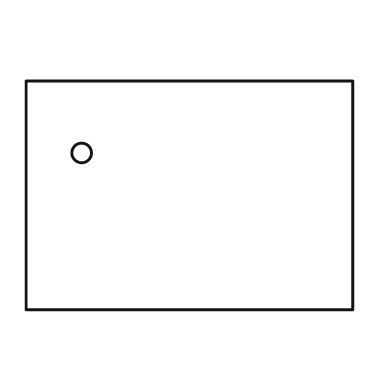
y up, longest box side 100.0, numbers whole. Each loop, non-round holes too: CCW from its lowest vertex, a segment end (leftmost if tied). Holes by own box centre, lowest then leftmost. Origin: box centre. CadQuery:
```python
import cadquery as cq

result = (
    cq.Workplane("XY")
    .moveTo(-50.0, -35.0)
    .lineTo(50.0, -35.0)
    .lineTo(50.0, 35.0)
    .lineTo(-50.0, 35.0)
    .close()
    .moveTo(-33.0, 13.0)
    .circle(3.0)
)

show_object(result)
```